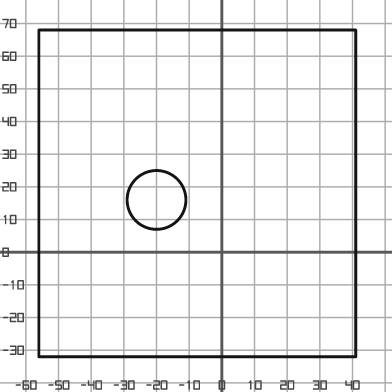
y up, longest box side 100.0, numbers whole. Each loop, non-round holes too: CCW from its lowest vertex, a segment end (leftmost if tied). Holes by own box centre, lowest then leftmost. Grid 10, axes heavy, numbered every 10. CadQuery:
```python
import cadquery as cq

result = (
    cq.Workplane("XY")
    .moveTo(-56.0, -32.0)
    .lineTo(41.0, -32.0)
    .lineTo(41.0, 68.0)
    .lineTo(-56.0, 68.0)
    .close()
    .moveTo(-20.0, 16.0)
    .circle(9.0)
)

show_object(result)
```